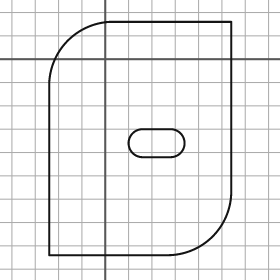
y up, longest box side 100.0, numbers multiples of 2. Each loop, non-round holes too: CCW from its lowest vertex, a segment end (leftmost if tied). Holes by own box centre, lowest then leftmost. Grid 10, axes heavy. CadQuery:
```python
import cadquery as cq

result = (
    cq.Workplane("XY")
    .moveTo(-24.0, -84.0)
    .lineTo(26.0, -84.0)
    .threePointArc((46.0, -76.0), (54.0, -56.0))
    .lineTo(54.0, 16.0)
    .lineTo(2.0, 16.0)
    .threePointArc((-16.0, 8.0), (-24.0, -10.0))
    .close()
    .moveTo(16.0, -42.0)
    .lineTo(28.0, -42.0)
    .threePointArc((34.0, -36.0), (28.0, -30.0))
    .lineTo(16.0, -30.0)
    .threePointArc((10.0, -36.0), (16.0, -42.0))
    .close()
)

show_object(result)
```